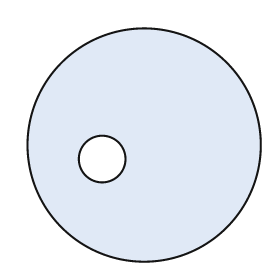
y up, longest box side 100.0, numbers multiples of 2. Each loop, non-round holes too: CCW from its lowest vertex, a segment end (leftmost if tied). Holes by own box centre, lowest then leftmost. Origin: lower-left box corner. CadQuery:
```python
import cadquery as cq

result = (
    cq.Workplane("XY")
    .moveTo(50.0, 50.0)
    .circle(50.0)
    .moveTo(32.0, 44.0)
    .circle(10.0)
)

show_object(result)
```